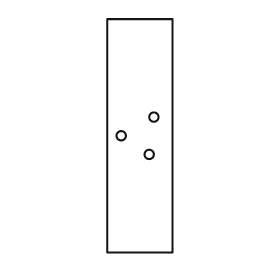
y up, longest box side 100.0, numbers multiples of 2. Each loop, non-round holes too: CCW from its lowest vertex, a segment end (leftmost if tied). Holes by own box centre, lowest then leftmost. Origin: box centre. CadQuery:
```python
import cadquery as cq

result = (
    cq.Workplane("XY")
    .moveTo(-14.0, -50.0)
    .lineTo(14.0, -50.0)
    .lineTo(14.0, 50.0)
    .lineTo(-14.0, 50.0)
    .close()
    .moveTo(4.0, -8.0)
    .circle(2.0)
    .moveTo(-8.0, 0.0)
    .circle(2.0)
    .moveTo(6.0, 8.0)
    .circle(2.0)
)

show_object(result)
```